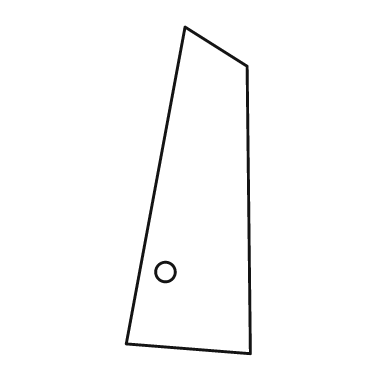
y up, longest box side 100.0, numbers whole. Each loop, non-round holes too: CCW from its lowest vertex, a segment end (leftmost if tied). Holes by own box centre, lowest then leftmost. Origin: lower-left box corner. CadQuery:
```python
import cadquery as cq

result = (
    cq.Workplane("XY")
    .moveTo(38.0, 0.0)
    .lineTo(37.0, 88.0)
    .lineTo(18.0, 100.0)
    .lineTo(0.0, 3.0)
    .close()
    .moveTo(12.0, 25.0)
    .circle(3.0)
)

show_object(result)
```